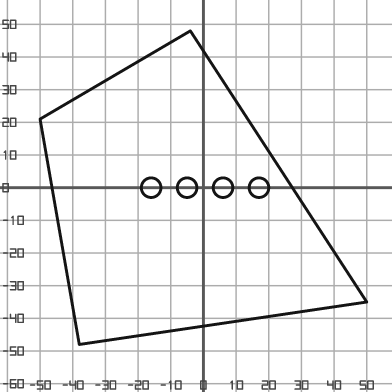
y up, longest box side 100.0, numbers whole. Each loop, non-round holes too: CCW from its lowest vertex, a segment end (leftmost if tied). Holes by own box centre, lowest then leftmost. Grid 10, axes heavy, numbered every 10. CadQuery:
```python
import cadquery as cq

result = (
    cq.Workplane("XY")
    .moveTo(-38.0, -48.0)
    .lineTo(50.0, -35.0)
    .lineTo(-4.0, 48.0)
    .lineTo(-50.0, 21.0)
    .close()
    .moveTo(-16.0, 0.0)
    .circle(3.0)
    .moveTo(-5.0, 0.0)
    .circle(3.0)
    .moveTo(6.0, 0.0)
    .circle(3.0)
    .moveTo(17.0, 0.0)
    .circle(3.0)
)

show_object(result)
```